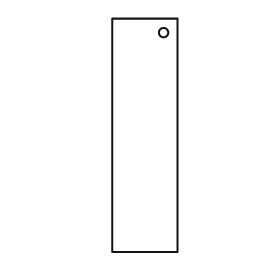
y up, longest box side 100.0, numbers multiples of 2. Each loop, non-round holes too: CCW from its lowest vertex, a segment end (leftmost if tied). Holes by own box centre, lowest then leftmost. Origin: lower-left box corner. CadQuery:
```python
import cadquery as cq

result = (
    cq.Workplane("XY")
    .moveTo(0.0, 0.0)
    .lineTo(28.0, 0.0)
    .lineTo(28.0, 100.0)
    .lineTo(0.0, 100.0)
    .close()
    .moveTo(22.0, 94.0)
    .circle(2.0)
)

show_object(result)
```